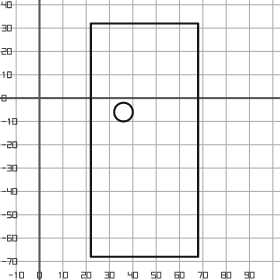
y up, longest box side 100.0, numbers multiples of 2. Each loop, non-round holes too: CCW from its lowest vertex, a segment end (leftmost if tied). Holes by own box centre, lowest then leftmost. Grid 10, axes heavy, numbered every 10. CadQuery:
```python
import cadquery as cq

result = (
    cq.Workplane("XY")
    .moveTo(22.0, -68.0)
    .lineTo(68.0, -68.0)
    .lineTo(68.0, 32.0)
    .lineTo(22.0, 32.0)
    .close()
    .moveTo(36.0, -6.0)
    .circle(4.0)
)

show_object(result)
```